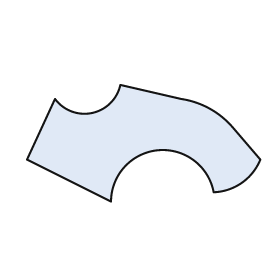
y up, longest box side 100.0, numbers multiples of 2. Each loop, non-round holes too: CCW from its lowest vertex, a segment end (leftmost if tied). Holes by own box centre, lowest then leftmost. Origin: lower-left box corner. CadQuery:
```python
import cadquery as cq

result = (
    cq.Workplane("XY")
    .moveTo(36.0, 0.0)
    .threePointArc((56.0, 22.0), (80.0, 4.0))
    .threePointArc((92.0, 8.0), (100.0, 18.0))
    .lineTo(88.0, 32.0)
    .threePointArc((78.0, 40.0), (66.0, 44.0))
    .lineTo(40.0, 50.0)
    .threePointArc((28.0, 38.0), (12.0, 44.0))
    .lineTo(0.0, 18.0)
    .close()
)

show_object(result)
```